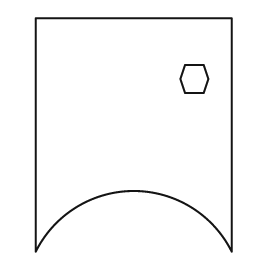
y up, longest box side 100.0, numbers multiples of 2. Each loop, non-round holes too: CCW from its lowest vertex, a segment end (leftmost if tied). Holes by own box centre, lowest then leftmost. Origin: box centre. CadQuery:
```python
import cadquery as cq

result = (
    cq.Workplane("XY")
    .moveTo(-42.0, -50.0)
    .threePointArc((0.0, -24.0), (42.0, -50.0))
    .lineTo(42.0, 50.0)
    .lineTo(-42.0, 50.0)
    .close()
    .moveTo(22.0, 18.0)
    .lineTo(30.0, 18.0)
    .lineTo(32.0, 24.0)
    .lineTo(30.0, 30.0)
    .lineTo(22.0, 30.0)
    .lineTo(20.0, 24.0)
    .close()
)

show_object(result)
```